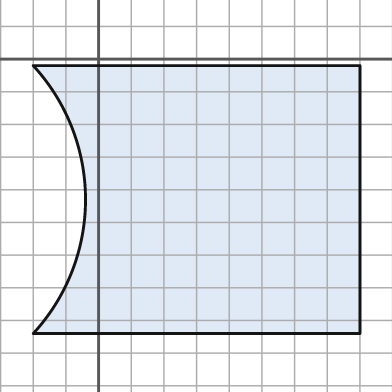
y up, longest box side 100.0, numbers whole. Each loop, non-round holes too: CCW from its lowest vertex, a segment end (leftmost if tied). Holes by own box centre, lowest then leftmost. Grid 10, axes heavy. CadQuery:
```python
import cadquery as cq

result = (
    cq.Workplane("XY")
    .moveTo(-20.0, -84.0)
    .lineTo(80.0, -84.0)
    .lineTo(80.0, -2.0)
    .lineTo(-20.0, -2.0)
    .threePointArc((-4.0, -43.0), (-20.0, -84.0))
    .close()
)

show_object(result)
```